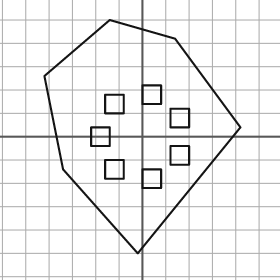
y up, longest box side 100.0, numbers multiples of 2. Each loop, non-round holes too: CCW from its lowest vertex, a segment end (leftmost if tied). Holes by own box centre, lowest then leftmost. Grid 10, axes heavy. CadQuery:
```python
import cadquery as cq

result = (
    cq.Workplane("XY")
    .moveTo(-2.0, -50.0)
    .lineTo(42.0, 4.0)
    .lineTo(14.0, 42.0)
    .lineTo(-14.0, 50.0)
    .lineTo(-42.0, 26.0)
    .lineTo(-34.0, -14.0)
    .close()
    .moveTo(0.0, -22.0)
    .lineTo(8.0, -22.0)
    .lineTo(8.0, -14.0)
    .lineTo(0.0, -14.0)
    .close()
    .moveTo(-16.0, -18.0)
    .lineTo(-8.0, -18.0)
    .lineTo(-8.0, -10.0)
    .lineTo(-16.0, -10.0)
    .close()
    .moveTo(12.0, -12.0)
    .lineTo(20.0, -12.0)
    .lineTo(20.0, -4.0)
    .lineTo(12.0, -4.0)
    .close()
    .moveTo(-22.0, -4.0)
    .lineTo(-14.0, -4.0)
    .lineTo(-14.0, 4.0)
    .lineTo(-22.0, 4.0)
    .close()
    .moveTo(12.0, 4.0)
    .lineTo(20.0, 4.0)
    .lineTo(20.0, 12.0)
    .lineTo(12.0, 12.0)
    .close()
    .moveTo(-16.0, 10.0)
    .lineTo(-8.0, 10.0)
    .lineTo(-8.0, 18.0)
    .lineTo(-16.0, 18.0)
    .close()
    .moveTo(0.0, 14.0)
    .lineTo(8.0, 14.0)
    .lineTo(8.0, 22.0)
    .lineTo(0.0, 22.0)
    .close()
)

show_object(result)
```